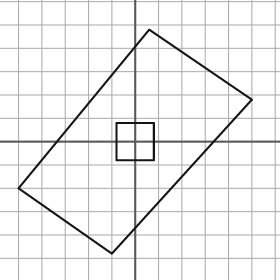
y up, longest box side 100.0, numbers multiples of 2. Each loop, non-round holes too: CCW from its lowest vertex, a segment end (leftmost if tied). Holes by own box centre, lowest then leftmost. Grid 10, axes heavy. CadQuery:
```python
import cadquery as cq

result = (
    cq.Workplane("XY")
    .moveTo(-10.0, -48.0)
    .lineTo(50.0, 18.0)
    .lineTo(6.0, 48.0)
    .lineTo(-50.0, -20.0)
    .close()
    .moveTo(-8.0, -8.0)
    .lineTo(8.0, -8.0)
    .lineTo(8.0, 8.0)
    .lineTo(-8.0, 8.0)
    .close()
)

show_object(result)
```